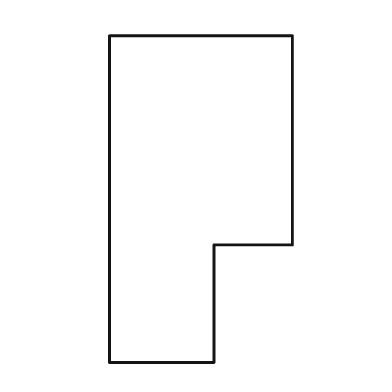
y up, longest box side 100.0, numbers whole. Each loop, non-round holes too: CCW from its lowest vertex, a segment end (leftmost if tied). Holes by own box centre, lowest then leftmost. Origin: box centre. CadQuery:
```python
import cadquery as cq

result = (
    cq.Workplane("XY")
    .moveTo(-28.0, -50.0)
    .lineTo(4.0, -50.0)
    .lineTo(4.0, -14.0)
    .lineTo(28.0, -14.0)
    .lineTo(28.0, 50.0)
    .lineTo(-28.0, 50.0)
    .close()
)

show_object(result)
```